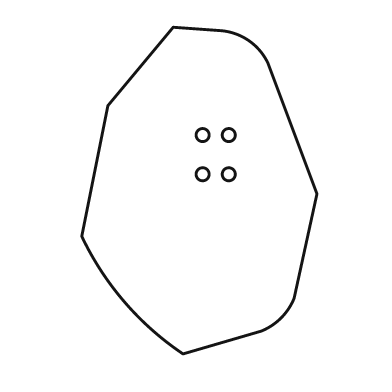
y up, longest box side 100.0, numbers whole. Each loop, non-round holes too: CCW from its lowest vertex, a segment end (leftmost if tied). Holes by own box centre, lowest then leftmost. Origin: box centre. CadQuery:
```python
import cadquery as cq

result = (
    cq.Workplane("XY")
    .moveTo(-5.0, -50.0)
    .lineTo(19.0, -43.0)
    .threePointArc((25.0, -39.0), (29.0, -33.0))
    .lineTo(36.0, -1.0)
    .lineTo(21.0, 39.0)
    .threePointArc((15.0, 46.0), (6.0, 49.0))
    .lineTo(-8.0, 50.0)
    .lineTo(-28.0, 26.0)
    .lineTo(-36.0, -14.0)
    .threePointArc((-23.0, -34.0), (-5.0, -50.0))
    .close()
    .moveTo(1.0, 5.0)
    .circle(2.0)
    .moveTo(9.0, 5.0)
    .circle(2.0)
    .moveTo(1.0, 17.0)
    .circle(2.0)
    .moveTo(9.0, 17.0)
    .circle(2.0)
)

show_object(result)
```